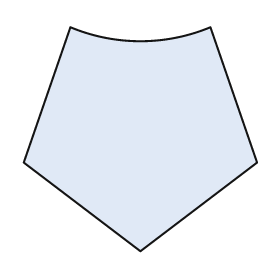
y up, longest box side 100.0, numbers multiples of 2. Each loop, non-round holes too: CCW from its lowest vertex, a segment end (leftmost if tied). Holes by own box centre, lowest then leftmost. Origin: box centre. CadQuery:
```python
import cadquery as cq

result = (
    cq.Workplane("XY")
    .moveTo(0.0, -48.0)
    .lineTo(50.0, -10.0)
    .lineTo(30.0, 48.0)
    .threePointArc((0.0, 42.0), (-30.0, 48.0))
    .lineTo(-50.0, -10.0)
    .close()
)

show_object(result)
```